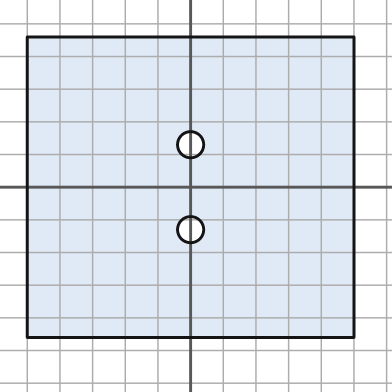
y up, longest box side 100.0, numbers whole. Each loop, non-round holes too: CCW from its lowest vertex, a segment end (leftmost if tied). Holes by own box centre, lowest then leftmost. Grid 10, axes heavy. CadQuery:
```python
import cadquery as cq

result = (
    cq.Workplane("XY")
    .moveTo(-50.0, -46.0)
    .lineTo(50.0, -46.0)
    .lineTo(50.0, 46.0)
    .lineTo(-50.0, 46.0)
    .close()
    .moveTo(0.0, -13.0)
    .circle(4.0)
    .moveTo(0.0, 13.0)
    .circle(4.0)
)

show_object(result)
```